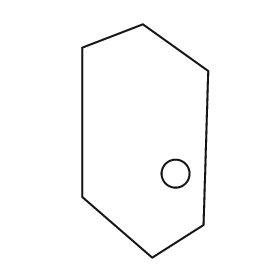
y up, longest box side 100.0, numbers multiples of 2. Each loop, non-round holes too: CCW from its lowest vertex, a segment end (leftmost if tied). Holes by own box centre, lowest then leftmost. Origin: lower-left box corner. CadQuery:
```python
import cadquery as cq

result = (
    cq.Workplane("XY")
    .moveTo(30.0, 0.0)
    .lineTo(52.0, 14.0)
    .lineTo(54.0, 80.0)
    .lineTo(26.0, 100.0)
    .lineTo(0.0, 90.0)
    .lineTo(0.0, 26.0)
    .close()
    .moveTo(40.0, 36.0)
    .circle(6.0)
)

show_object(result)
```